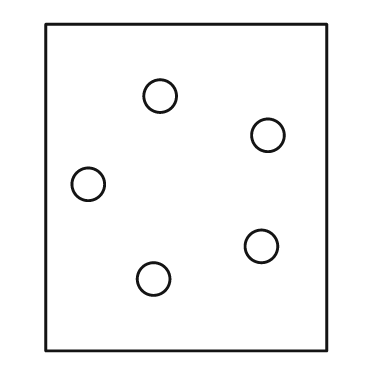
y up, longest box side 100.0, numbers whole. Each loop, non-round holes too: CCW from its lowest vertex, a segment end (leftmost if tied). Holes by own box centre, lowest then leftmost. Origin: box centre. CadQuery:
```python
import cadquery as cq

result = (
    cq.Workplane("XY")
    .moveTo(-43.0, -50.0)
    .lineTo(43.0, -50.0)
    .lineTo(43.0, 50.0)
    .lineTo(-43.0, 50.0)
    .close()
    .moveTo(-10.0, -28.0)
    .circle(5.0)
    .moveTo(23.0, -18.0)
    .circle(5.0)
    .moveTo(-30.0, 1.0)
    .circle(5.0)
    .moveTo(25.0, 16.0)
    .circle(5.0)
    .moveTo(-8.0, 28.0)
    .circle(5.0)
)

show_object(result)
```